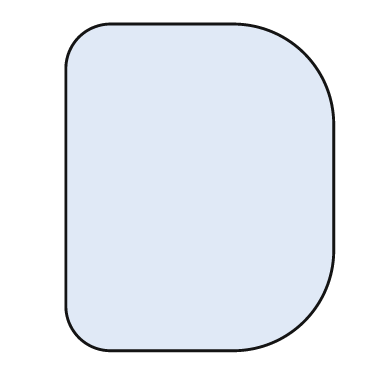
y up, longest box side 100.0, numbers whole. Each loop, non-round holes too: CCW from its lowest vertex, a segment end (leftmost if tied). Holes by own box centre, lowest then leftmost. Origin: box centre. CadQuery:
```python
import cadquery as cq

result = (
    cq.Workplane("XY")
    .moveTo(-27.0, -50.0)
    .lineTo(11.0, -50.0)
    .threePointArc((32.0, -41.0), (41.0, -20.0))
    .lineTo(41.0, 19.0)
    .threePointArc((32.0, 41.0), (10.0, 50.0))
    .lineTo(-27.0, 50.0)
    .threePointArc((-37.0, 46.0), (-41.0, 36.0))
    .lineTo(-41.0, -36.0)
    .threePointArc((-37.0, -46.0), (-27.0, -50.0))
    .close()
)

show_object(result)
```